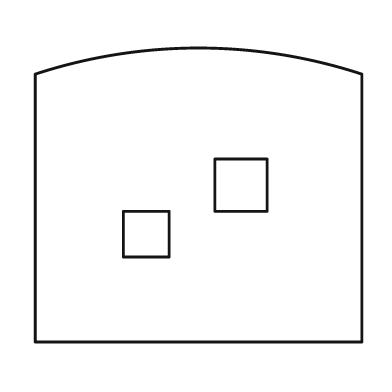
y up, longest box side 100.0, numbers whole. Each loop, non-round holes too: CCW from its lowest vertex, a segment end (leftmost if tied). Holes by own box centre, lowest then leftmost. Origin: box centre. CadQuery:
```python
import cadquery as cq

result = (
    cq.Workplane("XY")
    .moveTo(-50.0, -45.0)
    .lineTo(50.0, -45.0)
    .lineTo(50.0, 37.0)
    .threePointArc((0.0, 45.0), (-50.0, 37.0))
    .close()
    .moveTo(-23.0, -19.0)
    .lineTo(-9.0, -19.0)
    .lineTo(-9.0, -5.0)
    .lineTo(-23.0, -5.0)
    .close()
    .moveTo(5.0, -5.0)
    .lineTo(21.0, -5.0)
    .lineTo(21.0, 11.0)
    .lineTo(5.0, 11.0)
    .close()
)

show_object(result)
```